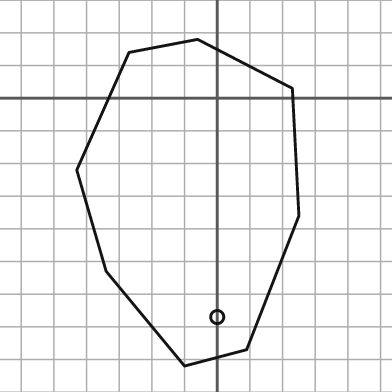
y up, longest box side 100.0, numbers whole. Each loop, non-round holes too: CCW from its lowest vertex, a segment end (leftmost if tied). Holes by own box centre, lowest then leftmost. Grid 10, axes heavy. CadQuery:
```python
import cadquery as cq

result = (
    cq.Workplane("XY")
    .moveTo(-10.0, -82.0)
    .lineTo(9.0, -77.0)
    .lineTo(25.0, -36.0)
    .lineTo(23.0, 3.0)
    .lineTo(-6.0, 18.0)
    .lineTo(-27.0, 14.0)
    .lineTo(-43.0, -22.0)
    .lineTo(-34.0, -53.0)
    .close()
    .moveTo(0.0, -67.0)
    .circle(2.0)
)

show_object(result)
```